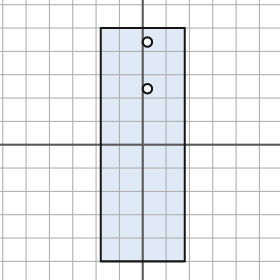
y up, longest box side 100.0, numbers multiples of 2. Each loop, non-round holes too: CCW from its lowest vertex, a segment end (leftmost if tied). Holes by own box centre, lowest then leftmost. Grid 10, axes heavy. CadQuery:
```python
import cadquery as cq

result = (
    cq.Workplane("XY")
    .moveTo(-18.0, -50.0)
    .lineTo(18.0, -50.0)
    .lineTo(18.0, 50.0)
    .lineTo(-18.0, 50.0)
    .close()
    .moveTo(2.0, 24.0)
    .circle(2.0)
    .moveTo(2.0, 44.0)
    .circle(2.0)
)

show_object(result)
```